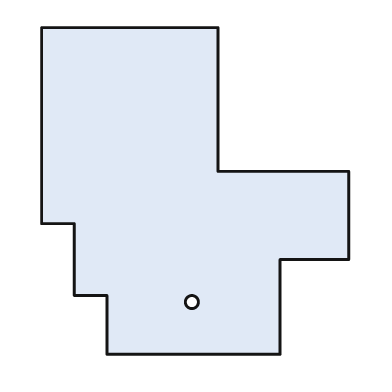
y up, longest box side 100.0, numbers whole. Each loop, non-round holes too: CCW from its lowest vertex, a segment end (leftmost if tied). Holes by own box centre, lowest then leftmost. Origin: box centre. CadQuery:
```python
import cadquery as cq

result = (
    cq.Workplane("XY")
    .moveTo(-27.0, -50.0)
    .lineTo(26.0, -50.0)
    .lineTo(26.0, -21.0)
    .lineTo(47.0, -21.0)
    .lineTo(47.0, 6.0)
    .lineTo(7.0, 6.0)
    .lineTo(7.0, 50.0)
    .lineTo(-47.0, 50.0)
    .lineTo(-47.0, -10.0)
    .lineTo(-37.0, -10.0)
    .lineTo(-37.0, -32.0)
    .lineTo(-27.0, -32.0)
    .close()
    .moveTo(-1.0, -34.0)
    .circle(2.0)
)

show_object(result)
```